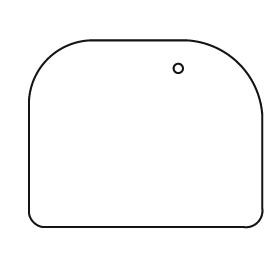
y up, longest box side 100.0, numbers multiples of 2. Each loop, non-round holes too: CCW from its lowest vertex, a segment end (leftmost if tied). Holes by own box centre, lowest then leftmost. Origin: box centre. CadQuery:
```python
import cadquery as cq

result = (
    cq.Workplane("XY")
    .moveTo(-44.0, -40.0)
    .lineTo(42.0, -40.0)
    .threePointArc((48.0, -38.0), (50.0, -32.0))
    .lineTo(50.0, 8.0)
    .threePointArc((40.0, 30.0), (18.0, 40.0))
    .lineTo(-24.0, 40.0)
    .threePointArc((-42.0, 32.0), (-50.0, 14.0))
    .lineTo(-50.0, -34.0)
    .threePointArc((-48.0, -38.0), (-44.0, -40.0))
    .close()
    .moveTo(14.0, 28.0)
    .circle(2.0)
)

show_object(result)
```